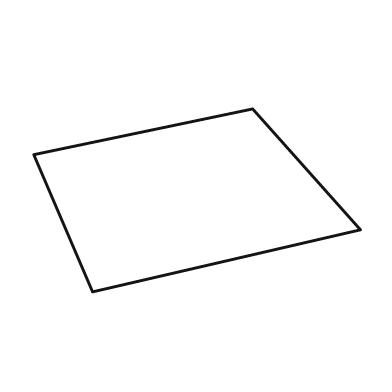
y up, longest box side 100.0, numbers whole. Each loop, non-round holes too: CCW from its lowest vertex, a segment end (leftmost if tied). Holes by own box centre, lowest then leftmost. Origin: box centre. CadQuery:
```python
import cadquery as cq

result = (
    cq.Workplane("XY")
    .moveTo(-32.0, -28.0)
    .lineTo(50.0, -9.0)
    .lineTo(17.0, 28.0)
    .lineTo(-50.0, 14.0)
    .close()
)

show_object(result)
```